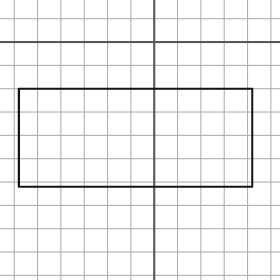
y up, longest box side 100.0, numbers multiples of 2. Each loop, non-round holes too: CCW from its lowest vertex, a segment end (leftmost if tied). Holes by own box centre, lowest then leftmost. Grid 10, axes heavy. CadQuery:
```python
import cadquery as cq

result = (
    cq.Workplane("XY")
    .moveTo(-58.0, -62.0)
    .lineTo(42.0, -62.0)
    .lineTo(42.0, -20.0)
    .lineTo(-58.0, -20.0)
    .close()
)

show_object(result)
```